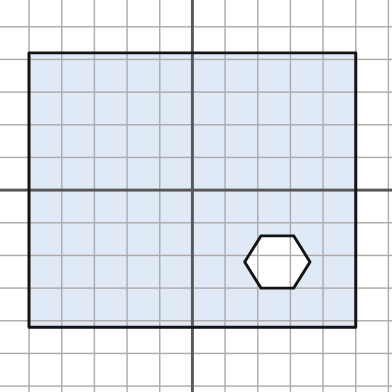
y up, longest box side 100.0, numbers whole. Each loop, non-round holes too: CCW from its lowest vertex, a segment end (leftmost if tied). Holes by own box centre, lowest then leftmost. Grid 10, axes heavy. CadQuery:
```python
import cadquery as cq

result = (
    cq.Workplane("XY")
    .moveTo(-50.0, -42.0)
    .lineTo(50.0, -42.0)
    .lineTo(50.0, 42.0)
    .lineTo(-50.0, 42.0)
    .close()
    .moveTo(21.0, -30.0)
    .lineTo(31.0, -30.0)
    .lineTo(36.0, -22.0)
    .lineTo(31.0, -14.0)
    .lineTo(21.0, -14.0)
    .lineTo(16.0, -22.0)
    .close()
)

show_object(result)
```